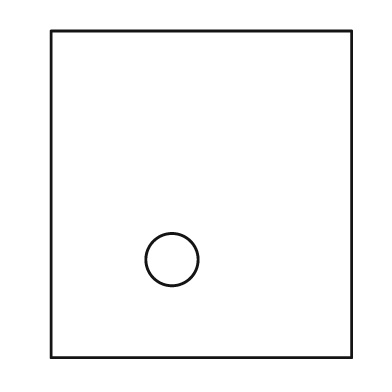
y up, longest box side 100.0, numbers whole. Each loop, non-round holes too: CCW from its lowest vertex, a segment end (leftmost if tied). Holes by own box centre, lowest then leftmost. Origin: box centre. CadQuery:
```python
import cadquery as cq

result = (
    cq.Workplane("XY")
    .moveTo(-46.0, -50.0)
    .lineTo(46.0, -50.0)
    .lineTo(46.0, 50.0)
    .lineTo(-46.0, 50.0)
    .close()
    .moveTo(-9.0, -20.0)
    .circle(8.0)
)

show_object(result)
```